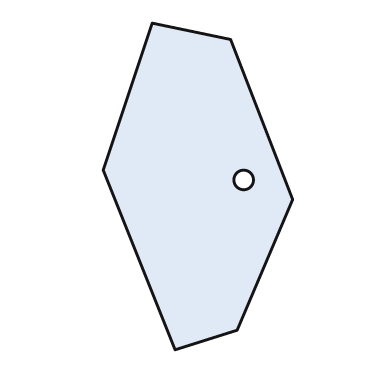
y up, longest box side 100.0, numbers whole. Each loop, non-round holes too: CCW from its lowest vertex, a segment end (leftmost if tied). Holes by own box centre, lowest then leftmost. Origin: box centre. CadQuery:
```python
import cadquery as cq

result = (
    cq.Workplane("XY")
    .moveTo(-7.0, -50.0)
    .lineTo(12.0, -44.0)
    .lineTo(29.0, -4.0)
    .lineTo(10.0, 45.0)
    .lineTo(-14.0, 50.0)
    .lineTo(-29.0, 5.0)
    .close()
    .moveTo(14.0, 2.0)
    .circle(3.0)
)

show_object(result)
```